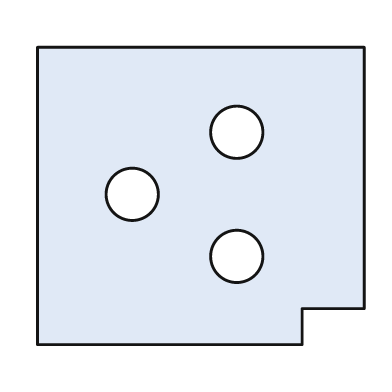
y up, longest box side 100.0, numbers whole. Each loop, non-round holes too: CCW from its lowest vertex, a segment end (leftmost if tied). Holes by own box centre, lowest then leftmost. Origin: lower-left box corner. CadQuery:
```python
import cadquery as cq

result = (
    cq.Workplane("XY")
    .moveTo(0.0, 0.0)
    .lineTo(81.0, 0.0)
    .lineTo(81.0, 11.0)
    .lineTo(100.0, 11.0)
    .lineTo(100.0, 91.0)
    .lineTo(0.0, 91.0)
    .close()
    .moveTo(61.0, 27.0)
    .circle(8.0)
    .moveTo(29.0, 46.0)
    .circle(8.0)
    .moveTo(61.0, 65.0)
    .circle(8.0)
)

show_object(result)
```